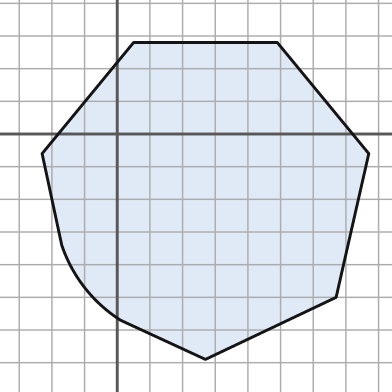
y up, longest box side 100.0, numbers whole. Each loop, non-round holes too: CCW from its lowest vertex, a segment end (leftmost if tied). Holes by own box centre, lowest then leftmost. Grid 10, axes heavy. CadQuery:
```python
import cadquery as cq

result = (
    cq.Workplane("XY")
    .moveTo(27.0, -69.0)
    .lineTo(67.0, -50.0)
    .lineTo(77.0, -6.0)
    .lineTo(49.0, 28.0)
    .lineTo(5.0, 28.0)
    .lineTo(-23.0, -6.0)
    .lineTo(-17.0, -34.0)
    .threePointArc((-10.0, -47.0), (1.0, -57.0))
    .close()
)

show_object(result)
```